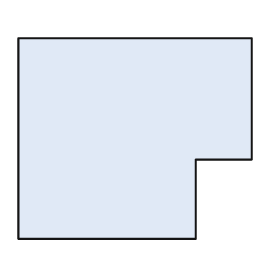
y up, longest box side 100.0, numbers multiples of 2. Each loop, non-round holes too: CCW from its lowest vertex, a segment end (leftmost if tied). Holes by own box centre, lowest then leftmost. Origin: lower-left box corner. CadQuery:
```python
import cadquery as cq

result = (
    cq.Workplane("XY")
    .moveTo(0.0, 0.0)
    .lineTo(76.0, 0.0)
    .lineTo(76.0, 34.0)
    .lineTo(100.0, 34.0)
    .lineTo(100.0, 86.0)
    .lineTo(0.0, 86.0)
    .close()
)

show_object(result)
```